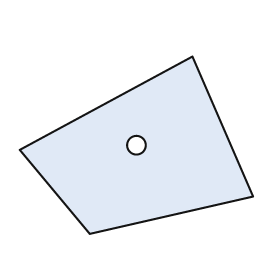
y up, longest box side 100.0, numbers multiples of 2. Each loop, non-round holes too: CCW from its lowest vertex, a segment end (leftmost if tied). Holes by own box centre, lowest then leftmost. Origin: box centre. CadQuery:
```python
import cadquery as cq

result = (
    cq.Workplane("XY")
    .moveTo(-20.0, -38.0)
    .lineTo(50.0, -22.0)
    .lineTo(24.0, 38.0)
    .lineTo(-50.0, -2.0)
    .close()
    .moveTo(0.0, 0.0)
    .circle(4.0)
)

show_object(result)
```